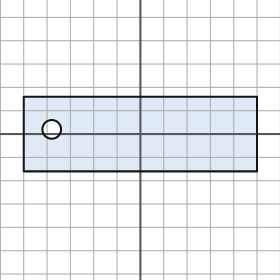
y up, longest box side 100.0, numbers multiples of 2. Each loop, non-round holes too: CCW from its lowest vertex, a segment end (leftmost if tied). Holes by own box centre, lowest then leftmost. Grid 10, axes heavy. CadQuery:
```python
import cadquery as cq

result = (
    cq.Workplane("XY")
    .moveTo(-50.0, -16.0)
    .lineTo(50.0, -16.0)
    .lineTo(50.0, 16.0)
    .lineTo(-50.0, 16.0)
    .close()
    .moveTo(-38.0, 2.0)
    .circle(4.0)
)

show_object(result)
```